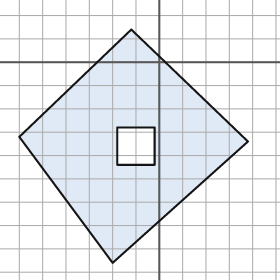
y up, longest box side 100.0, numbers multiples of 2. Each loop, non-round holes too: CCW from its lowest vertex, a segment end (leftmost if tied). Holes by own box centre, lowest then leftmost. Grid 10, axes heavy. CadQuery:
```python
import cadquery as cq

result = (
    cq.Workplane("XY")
    .moveTo(-20.0, -86.0)
    .lineTo(38.0, -34.0)
    .lineTo(-12.0, 14.0)
    .lineTo(-60.0, -32.0)
    .close()
    .moveTo(-18.0, -44.0)
    .lineTo(-2.0, -44.0)
    .lineTo(-2.0, -28.0)
    .lineTo(-18.0, -28.0)
    .close()
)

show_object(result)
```